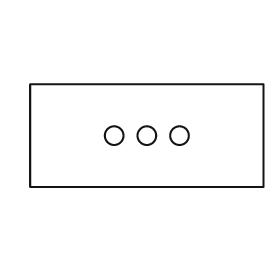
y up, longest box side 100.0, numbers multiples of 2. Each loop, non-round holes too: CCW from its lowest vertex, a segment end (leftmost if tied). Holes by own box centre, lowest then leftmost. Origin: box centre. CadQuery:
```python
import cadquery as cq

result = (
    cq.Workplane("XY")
    .moveTo(-50.0, -22.0)
    .lineTo(50.0, -22.0)
    .lineTo(50.0, 22.0)
    .lineTo(-50.0, 22.0)
    .close()
    .moveTo(-14.0, 0.0)
    .circle(4.0)
    .moveTo(0.0, 0.0)
    .circle(4.0)
    .moveTo(14.0, 0.0)
    .circle(4.0)
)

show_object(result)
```